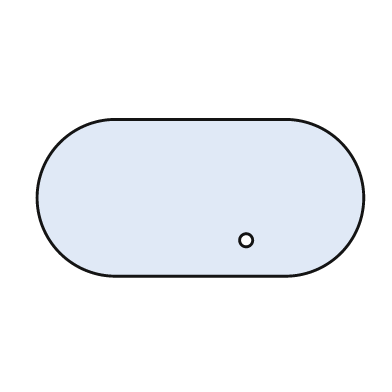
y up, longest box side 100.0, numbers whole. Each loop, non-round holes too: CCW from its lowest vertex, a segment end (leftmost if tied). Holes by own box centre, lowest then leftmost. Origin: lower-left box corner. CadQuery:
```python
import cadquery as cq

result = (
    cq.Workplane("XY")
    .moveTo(24.0, 0.0)
    .lineTo(76.0, 0.0)
    .threePointArc((100.0, 24.0), (76.0, 48.0))
    .lineTo(24.0, 48.0)
    .threePointArc((0.0, 24.0), (24.0, 0.0))
    .close()
    .moveTo(64.0, 11.0)
    .circle(2.0)
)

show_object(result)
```